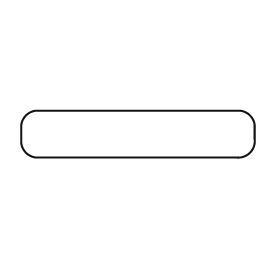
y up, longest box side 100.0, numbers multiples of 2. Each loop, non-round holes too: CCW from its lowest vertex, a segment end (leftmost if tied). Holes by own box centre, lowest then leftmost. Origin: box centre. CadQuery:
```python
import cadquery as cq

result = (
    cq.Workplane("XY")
    .moveTo(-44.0, -10.0)
    .lineTo(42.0, -10.0)
    .threePointArc((48.0, -8.0), (50.0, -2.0))
    .lineTo(50.0, 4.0)
    .threePointArc((48.0, 8.0), (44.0, 10.0))
    .lineTo(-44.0, 10.0)
    .threePointArc((-48.0, 8.0), (-50.0, 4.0))
    .lineTo(-50.0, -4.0)
    .threePointArc((-48.0, -8.0), (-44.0, -10.0))
    .close()
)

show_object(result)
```